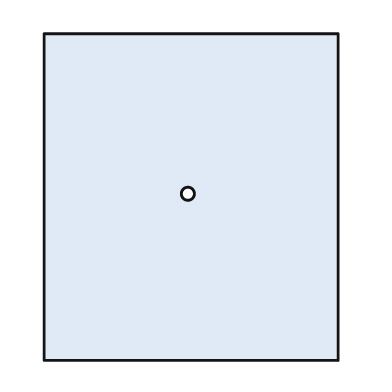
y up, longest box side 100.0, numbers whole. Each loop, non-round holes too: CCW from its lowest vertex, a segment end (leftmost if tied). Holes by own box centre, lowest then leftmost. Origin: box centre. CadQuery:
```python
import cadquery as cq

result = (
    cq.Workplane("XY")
    .moveTo(-45.0, -50.0)
    .lineTo(45.0, -50.0)
    .lineTo(45.0, 50.0)
    .lineTo(-45.0, 50.0)
    .close()
    .moveTo(-1.0, 1.0)
    .circle(2.0)
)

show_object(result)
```